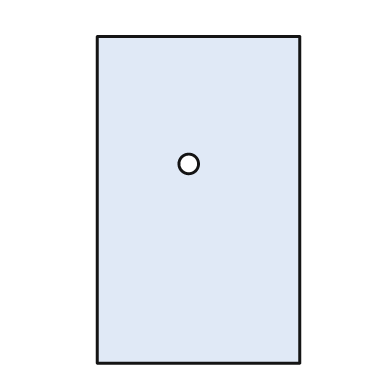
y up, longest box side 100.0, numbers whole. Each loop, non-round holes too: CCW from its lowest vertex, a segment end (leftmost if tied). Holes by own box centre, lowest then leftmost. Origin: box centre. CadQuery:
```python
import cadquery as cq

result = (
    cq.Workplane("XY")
    .moveTo(-31.0, -50.0)
    .lineTo(31.0, -50.0)
    .lineTo(31.0, 50.0)
    .lineTo(-31.0, 50.0)
    .close()
    .moveTo(-3.0, 11.0)
    .circle(3.0)
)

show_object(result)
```